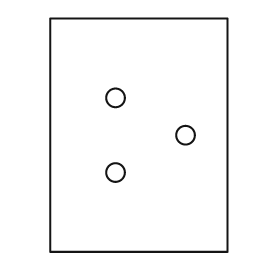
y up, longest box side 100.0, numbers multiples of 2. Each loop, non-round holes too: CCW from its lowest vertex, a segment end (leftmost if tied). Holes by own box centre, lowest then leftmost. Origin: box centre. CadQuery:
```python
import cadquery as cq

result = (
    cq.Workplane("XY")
    .moveTo(-38.0, -50.0)
    .lineTo(38.0, -50.0)
    .lineTo(38.0, 50.0)
    .lineTo(-38.0, 50.0)
    .close()
    .moveTo(-10.0, -16.0)
    .circle(4.0)
    .moveTo(20.0, 0.0)
    .circle(4.0)
    .moveTo(-10.0, 16.0)
    .circle(4.0)
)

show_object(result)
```